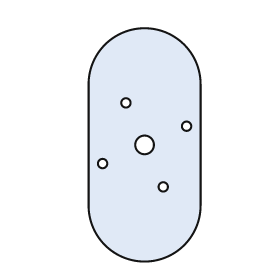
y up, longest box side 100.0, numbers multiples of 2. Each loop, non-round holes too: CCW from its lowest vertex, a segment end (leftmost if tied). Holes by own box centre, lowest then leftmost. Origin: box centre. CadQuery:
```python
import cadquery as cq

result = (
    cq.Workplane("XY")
    .moveTo(-24.0, -26.0)
    .threePointArc((0.0, -50.0), (24.0, -26.0))
    .lineTo(24.0, 26.0)
    .threePointArc((0.0, 50.0), (-24.0, 26.0))
    .close()
    .moveTo(8.0, -18.0)
    .circle(2.0)
    .moveTo(-18.0, -8.0)
    .circle(2.0)
    .moveTo(0.0, 0.0)
    .circle(4.0)
    .moveTo(18.0, 8.0)
    .circle(2.0)
    .moveTo(-8.0, 18.0)
    .circle(2.0)
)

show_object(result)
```